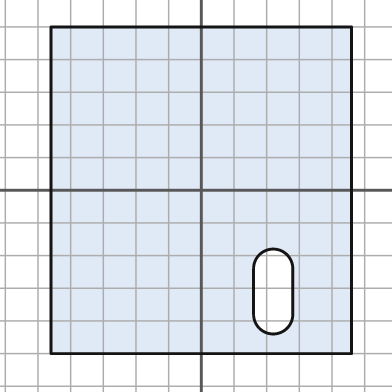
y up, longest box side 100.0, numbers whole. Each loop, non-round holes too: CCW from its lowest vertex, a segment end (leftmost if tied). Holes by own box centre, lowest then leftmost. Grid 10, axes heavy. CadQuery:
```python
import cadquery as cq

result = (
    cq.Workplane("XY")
    .moveTo(-46.0, -50.0)
    .lineTo(46.0, -50.0)
    .lineTo(46.0, 50.0)
    .lineTo(-46.0, 50.0)
    .close()
    .moveTo(16.0, -38.0)
    .threePointArc((22.0, -44.0), (28.0, -38.0))
    .lineTo(28.0, -24.0)
    .threePointArc((22.0, -18.0), (16.0, -24.0))
    .close()
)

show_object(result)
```